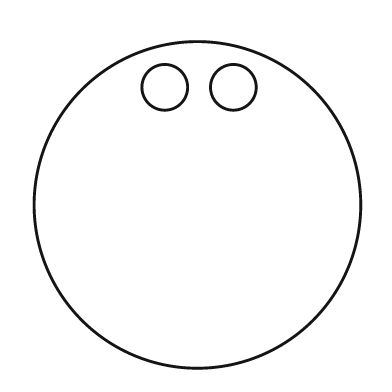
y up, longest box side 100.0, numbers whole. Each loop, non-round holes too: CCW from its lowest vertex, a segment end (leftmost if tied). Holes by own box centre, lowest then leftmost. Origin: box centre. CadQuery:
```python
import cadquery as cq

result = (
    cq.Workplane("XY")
    .moveTo(0.0, 0.0)
    .circle(50.0)
    .moveTo(-10.0, 36.0)
    .circle(7.0)
    .moveTo(11.0, 36.0)
    .circle(7.0)
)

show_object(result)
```